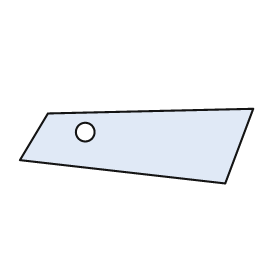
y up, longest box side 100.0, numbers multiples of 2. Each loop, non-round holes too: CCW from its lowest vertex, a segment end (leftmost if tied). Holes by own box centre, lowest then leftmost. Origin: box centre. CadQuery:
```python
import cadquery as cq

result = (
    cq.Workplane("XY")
    .moveTo(38.0, -16.0)
    .lineTo(50.0, 16.0)
    .lineTo(-38.0, 14.0)
    .lineTo(-50.0, -6.0)
    .close()
    .moveTo(-22.0, 6.0)
    .circle(4.0)
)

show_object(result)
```